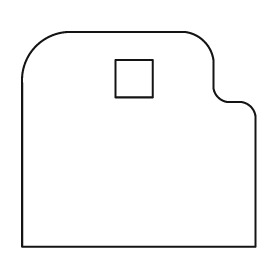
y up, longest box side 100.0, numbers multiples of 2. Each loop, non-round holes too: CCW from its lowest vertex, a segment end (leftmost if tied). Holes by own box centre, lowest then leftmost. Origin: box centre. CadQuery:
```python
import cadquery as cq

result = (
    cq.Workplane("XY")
    .moveTo(-50.0, -46.0)
    .lineTo(50.0, -46.0)
    .lineTo(50.0, 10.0)
    .threePointArc((48.0, 14.0), (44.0, 16.0))
    .lineTo(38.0, 16.0)
    .threePointArc((34.0, 18.0), (32.0, 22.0))
    .lineTo(32.0, 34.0)
    .threePointArc((28.0, 42.0), (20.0, 46.0))
    .lineTo(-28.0, 46.0)
    .threePointArc((-44.0, 40.0), (-50.0, 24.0))
    .close()
    .moveTo(-10.0, 18.0)
    .lineTo(6.0, 18.0)
    .lineTo(6.0, 34.0)
    .lineTo(-10.0, 34.0)
    .close()
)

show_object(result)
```